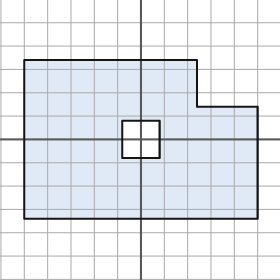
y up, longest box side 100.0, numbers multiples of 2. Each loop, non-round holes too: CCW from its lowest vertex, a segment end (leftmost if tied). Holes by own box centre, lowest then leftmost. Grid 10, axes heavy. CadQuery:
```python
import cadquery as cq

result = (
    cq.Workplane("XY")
    .moveTo(-50.0, -34.0)
    .lineTo(50.0, -34.0)
    .lineTo(50.0, 14.0)
    .lineTo(24.0, 14.0)
    .lineTo(24.0, 34.0)
    .lineTo(-50.0, 34.0)
    .close()
    .moveTo(-8.0, -8.0)
    .lineTo(8.0, -8.0)
    .lineTo(8.0, 8.0)
    .lineTo(-8.0, 8.0)
    .close()
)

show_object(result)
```